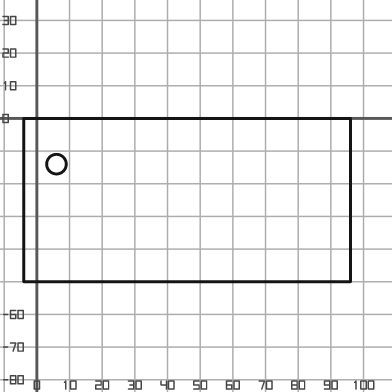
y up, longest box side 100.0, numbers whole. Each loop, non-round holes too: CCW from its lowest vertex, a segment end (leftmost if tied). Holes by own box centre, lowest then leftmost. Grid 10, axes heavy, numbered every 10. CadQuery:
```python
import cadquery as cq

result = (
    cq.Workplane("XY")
    .moveTo(-4.0, -50.0)
    .lineTo(96.0, -50.0)
    .lineTo(96.0, 0.0)
    .lineTo(-4.0, 0.0)
    .close()
    .moveTo(6.0, -14.0)
    .circle(3.0)
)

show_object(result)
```